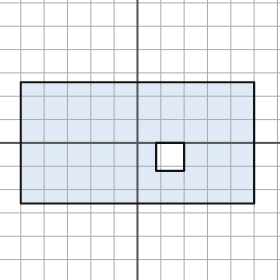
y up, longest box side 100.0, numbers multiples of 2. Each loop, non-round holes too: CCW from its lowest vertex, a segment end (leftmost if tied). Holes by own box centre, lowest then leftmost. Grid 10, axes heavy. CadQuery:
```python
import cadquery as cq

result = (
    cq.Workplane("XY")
    .moveTo(-50.0, -26.0)
    .lineTo(50.0, -26.0)
    .lineTo(50.0, 26.0)
    .lineTo(-50.0, 26.0)
    .close()
    .moveTo(8.0, -12.0)
    .lineTo(20.0, -12.0)
    .lineTo(20.0, 0.0)
    .lineTo(8.0, 0.0)
    .close()
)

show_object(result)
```